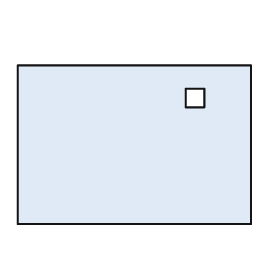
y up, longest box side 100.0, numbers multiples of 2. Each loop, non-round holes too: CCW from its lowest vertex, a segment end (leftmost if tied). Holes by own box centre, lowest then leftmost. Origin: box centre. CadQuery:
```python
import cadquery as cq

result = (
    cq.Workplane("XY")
    .moveTo(-50.0, -34.0)
    .lineTo(50.0, -34.0)
    .lineTo(50.0, 34.0)
    .lineTo(-50.0, 34.0)
    .close()
    .moveTo(22.0, 16.0)
    .lineTo(30.0, 16.0)
    .lineTo(30.0, 24.0)
    .lineTo(22.0, 24.0)
    .close()
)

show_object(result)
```